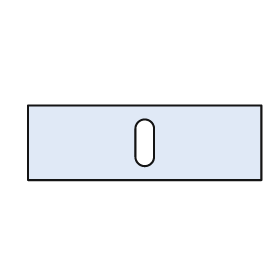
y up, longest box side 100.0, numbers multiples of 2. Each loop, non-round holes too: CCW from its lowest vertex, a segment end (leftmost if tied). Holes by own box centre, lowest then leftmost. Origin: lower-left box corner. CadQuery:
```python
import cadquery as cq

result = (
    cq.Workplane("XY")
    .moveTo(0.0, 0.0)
    .lineTo(100.0, 0.0)
    .lineTo(100.0, 32.0)
    .lineTo(0.0, 32.0)
    .close()
    .moveTo(46.0, 10.0)
    .threePointArc((50.0, 6.0), (54.0, 10.0))
    .lineTo(54.0, 22.0)
    .threePointArc((50.0, 26.0), (46.0, 22.0))
    .close()
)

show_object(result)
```